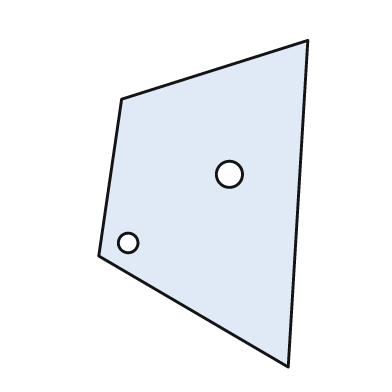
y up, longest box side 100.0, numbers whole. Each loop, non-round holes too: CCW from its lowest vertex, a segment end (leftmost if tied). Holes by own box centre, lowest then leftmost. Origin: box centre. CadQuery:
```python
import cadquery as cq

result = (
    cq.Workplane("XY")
    .moveTo(26.0, -50.0)
    .lineTo(32.0, 50.0)
    .lineTo(-25.0, 32.0)
    .lineTo(-32.0, -16.0)
    .close()
    .moveTo(-23.0, -12.0)
    .circle(3.0)
    .moveTo(8.0, 9.0)
    .circle(4.0)
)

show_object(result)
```